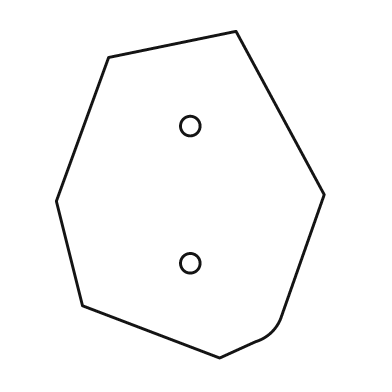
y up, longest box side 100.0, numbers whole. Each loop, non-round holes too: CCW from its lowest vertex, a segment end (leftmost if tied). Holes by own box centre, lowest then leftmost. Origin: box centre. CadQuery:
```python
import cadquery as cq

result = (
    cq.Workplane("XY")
    .moveTo(9.0, -50.0)
    .lineTo(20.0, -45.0)
    .threePointArc((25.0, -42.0), (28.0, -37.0))
    .lineTo(41.0, 0.0)
    .lineTo(14.0, 50.0)
    .lineTo(-25.0, 42.0)
    .lineTo(-41.0, -2.0)
    .lineTo(-33.0, -34.0)
    .close()
    .moveTo(0.0, -21.0)
    .circle(3.0)
    .moveTo(0.0, 21.0)
    .circle(3.0)
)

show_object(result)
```